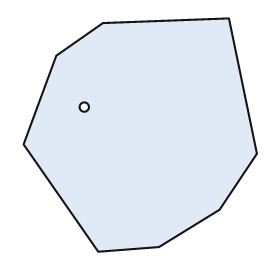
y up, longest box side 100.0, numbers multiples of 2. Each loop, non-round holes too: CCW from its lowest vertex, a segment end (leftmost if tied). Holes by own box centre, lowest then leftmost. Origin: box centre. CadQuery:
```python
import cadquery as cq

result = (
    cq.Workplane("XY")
    .moveTo(-18.0, -50.0)
    .lineTo(8.0, -48.0)
    .lineTo(34.0, -32.0)
    .lineTo(50.0, -8.0)
    .lineTo(38.0, 50.0)
    .lineTo(-16.0, 48.0)
    .lineTo(-36.0, 34.0)
    .lineTo(-50.0, -4.0)
    .close()
    .moveTo(-24.0, 12.0)
    .circle(2.0)
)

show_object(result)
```